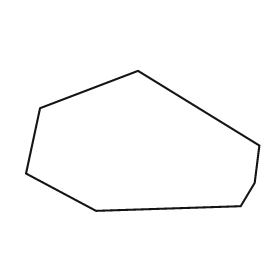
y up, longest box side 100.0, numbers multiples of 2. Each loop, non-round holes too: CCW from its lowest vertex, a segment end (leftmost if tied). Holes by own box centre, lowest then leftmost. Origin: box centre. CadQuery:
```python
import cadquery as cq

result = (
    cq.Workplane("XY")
    .moveTo(-20.0, -30.0)
    .lineTo(42.0, -28.0)
    .lineTo(48.0, -18.0)
    .lineTo(50.0, -2.0)
    .lineTo(-2.0, 30.0)
    .lineTo(-44.0, 14.0)
    .lineTo(-50.0, -14.0)
    .close()
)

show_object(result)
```